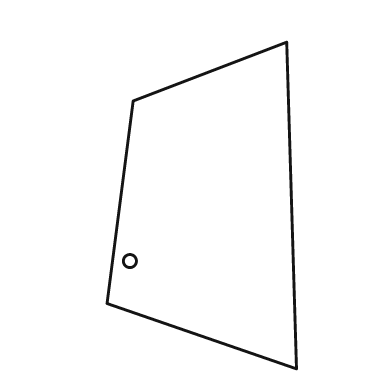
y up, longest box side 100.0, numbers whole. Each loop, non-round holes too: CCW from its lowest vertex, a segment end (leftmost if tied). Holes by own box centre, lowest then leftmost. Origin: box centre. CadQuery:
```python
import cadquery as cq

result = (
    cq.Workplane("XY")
    .moveTo(29.0, -50.0)
    .lineTo(26.0, 50.0)
    .lineTo(-21.0, 32.0)
    .lineTo(-29.0, -30.0)
    .close()
    .moveTo(-22.0, -17.0)
    .circle(2.0)
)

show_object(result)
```